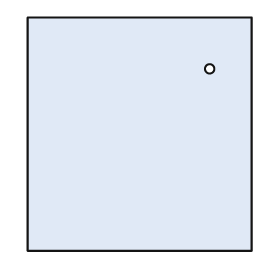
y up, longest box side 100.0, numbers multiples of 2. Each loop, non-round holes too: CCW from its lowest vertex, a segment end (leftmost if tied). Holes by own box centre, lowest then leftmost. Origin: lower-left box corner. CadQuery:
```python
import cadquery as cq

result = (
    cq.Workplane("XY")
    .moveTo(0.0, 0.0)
    .lineTo(96.0, 0.0)
    .lineTo(96.0, 100.0)
    .lineTo(0.0, 100.0)
    .close()
    .moveTo(78.0, 78.0)
    .circle(2.0)
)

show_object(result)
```